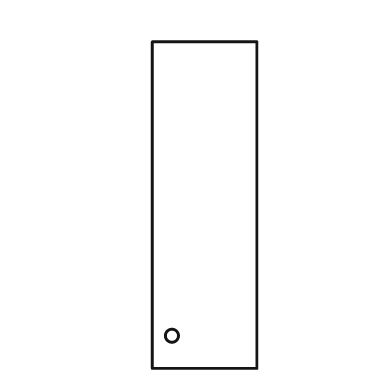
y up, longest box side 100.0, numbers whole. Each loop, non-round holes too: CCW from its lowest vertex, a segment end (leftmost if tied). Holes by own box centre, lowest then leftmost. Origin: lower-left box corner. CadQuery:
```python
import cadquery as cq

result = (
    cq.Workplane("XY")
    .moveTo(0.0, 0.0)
    .lineTo(32.0, 0.0)
    .lineTo(32.0, 100.0)
    .lineTo(0.0, 100.0)
    .close()
    .moveTo(6.0, 10.0)
    .circle(2.0)
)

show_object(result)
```